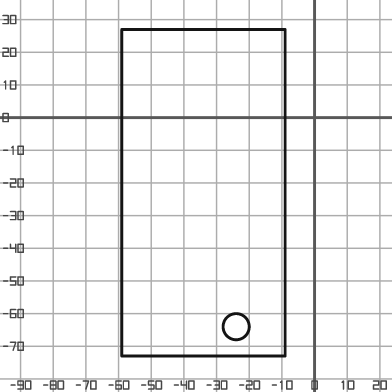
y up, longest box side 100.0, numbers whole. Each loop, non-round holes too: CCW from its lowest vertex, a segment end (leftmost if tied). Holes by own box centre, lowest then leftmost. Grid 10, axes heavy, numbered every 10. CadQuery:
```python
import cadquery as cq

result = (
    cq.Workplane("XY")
    .moveTo(-59.0, -73.0)
    .lineTo(-9.0, -73.0)
    .lineTo(-9.0, 27.0)
    .lineTo(-59.0, 27.0)
    .close()
    .moveTo(-24.0, -64.0)
    .circle(4.0)
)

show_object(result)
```